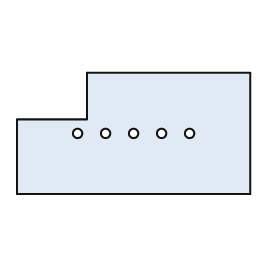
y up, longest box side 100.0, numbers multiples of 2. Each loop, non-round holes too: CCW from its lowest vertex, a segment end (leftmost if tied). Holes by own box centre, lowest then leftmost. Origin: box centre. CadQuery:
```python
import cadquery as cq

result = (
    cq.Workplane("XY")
    .moveTo(-50.0, -26.0)
    .lineTo(50.0, -26.0)
    .lineTo(50.0, 26.0)
    .lineTo(-20.0, 26.0)
    .lineTo(-20.0, 6.0)
    .lineTo(-50.0, 6.0)
    .close()
    .moveTo(-24.0, 0.0)
    .circle(2.0)
    .moveTo(-12.0, 0.0)
    .circle(2.0)
    .moveTo(0.0, 0.0)
    .circle(2.0)
    .moveTo(12.0, 0.0)
    .circle(2.0)
    .moveTo(24.0, 0.0)
    .circle(2.0)
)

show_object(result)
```